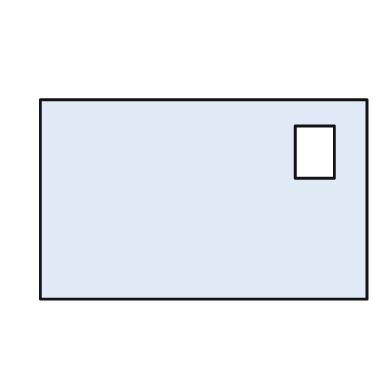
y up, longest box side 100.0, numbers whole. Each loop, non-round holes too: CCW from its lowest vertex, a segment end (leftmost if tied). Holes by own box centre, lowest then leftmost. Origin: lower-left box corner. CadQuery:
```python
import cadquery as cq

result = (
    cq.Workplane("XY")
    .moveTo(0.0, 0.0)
    .lineTo(100.0, 0.0)
    .lineTo(100.0, 61.0)
    .lineTo(0.0, 61.0)
    .close()
    .moveTo(78.0, 37.0)
    .lineTo(90.0, 37.0)
    .lineTo(90.0, 53.0)
    .lineTo(78.0, 53.0)
    .close()
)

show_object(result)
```